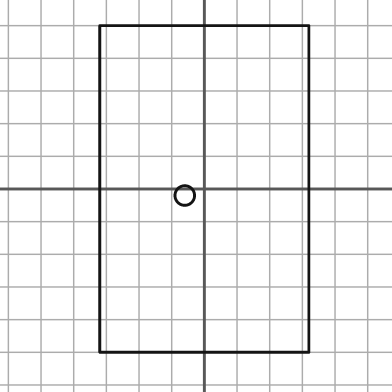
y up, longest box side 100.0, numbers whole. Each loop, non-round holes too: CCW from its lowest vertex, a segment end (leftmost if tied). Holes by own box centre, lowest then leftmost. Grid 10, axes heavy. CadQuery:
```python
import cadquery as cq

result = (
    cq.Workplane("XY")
    .moveTo(-32.0, -50.0)
    .lineTo(32.0, -50.0)
    .lineTo(32.0, 50.0)
    .lineTo(-32.0, 50.0)
    .close()
    .moveTo(-6.0, -2.0)
    .circle(3.0)
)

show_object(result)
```